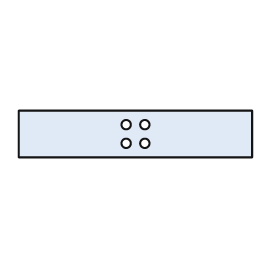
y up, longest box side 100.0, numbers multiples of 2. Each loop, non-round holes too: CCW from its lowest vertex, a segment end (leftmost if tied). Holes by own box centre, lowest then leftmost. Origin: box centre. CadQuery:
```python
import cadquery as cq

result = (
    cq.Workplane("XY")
    .moveTo(-50.0, -10.0)
    .lineTo(50.0, -10.0)
    .lineTo(50.0, 10.0)
    .lineTo(-50.0, 10.0)
    .close()
    .moveTo(-4.0, -4.0)
    .circle(2.0)
    .moveTo(4.0, -4.0)
    .circle(2.0)
    .moveTo(-4.0, 4.0)
    .circle(2.0)
    .moveTo(4.0, 4.0)
    .circle(2.0)
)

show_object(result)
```